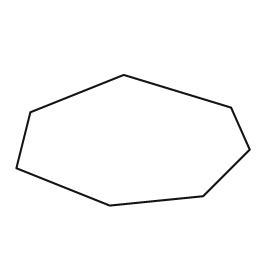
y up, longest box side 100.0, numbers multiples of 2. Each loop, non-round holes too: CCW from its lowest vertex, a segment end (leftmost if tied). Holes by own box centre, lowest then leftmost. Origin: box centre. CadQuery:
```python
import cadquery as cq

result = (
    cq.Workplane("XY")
    .moveTo(-10.0, -28.0)
    .lineTo(30.0, -24.0)
    .lineTo(50.0, -4.0)
    .lineTo(42.0, 14.0)
    .lineTo(-4.0, 28.0)
    .lineTo(-44.0, 12.0)
    .lineTo(-50.0, -12.0)
    .close()
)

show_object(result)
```